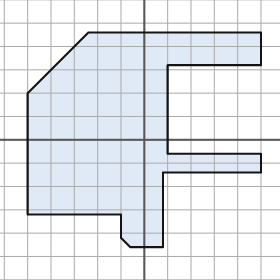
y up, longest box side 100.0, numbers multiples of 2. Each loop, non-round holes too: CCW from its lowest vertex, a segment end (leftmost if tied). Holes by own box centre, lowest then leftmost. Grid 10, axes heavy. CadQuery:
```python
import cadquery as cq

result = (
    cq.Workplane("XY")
    .moveTo(-6.0, -46.0)
    .lineTo(8.0, -46.0)
    .lineTo(8.0, -14.0)
    .lineTo(50.0, -14.0)
    .lineTo(50.0, -6.0)
    .lineTo(10.0, -6.0)
    .lineTo(10.0, 32.0)
    .lineTo(50.0, 32.0)
    .lineTo(50.0, 46.0)
    .lineTo(-24.0, 46.0)
    .lineTo(-50.0, 20.0)
    .lineTo(-50.0, -32.0)
    .lineTo(-10.0, -32.0)
    .lineTo(-10.0, -42.0)
    .close()
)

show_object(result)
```